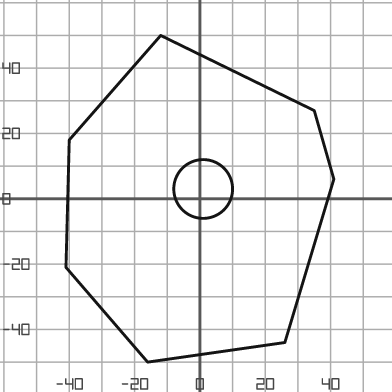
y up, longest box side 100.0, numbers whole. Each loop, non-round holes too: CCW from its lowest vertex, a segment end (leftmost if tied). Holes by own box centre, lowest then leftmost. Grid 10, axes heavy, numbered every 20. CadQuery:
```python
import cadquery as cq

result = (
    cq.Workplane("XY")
    .moveTo(-16.0, -50.0)
    .lineTo(26.0, -44.0)
    .lineTo(41.0, 6.0)
    .lineTo(35.0, 27.0)
    .lineTo(-12.0, 50.0)
    .lineTo(-40.0, 18.0)
    .lineTo(-41.0, -21.0)
    .close()
    .moveTo(1.0, 3.0)
    .circle(9.0)
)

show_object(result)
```